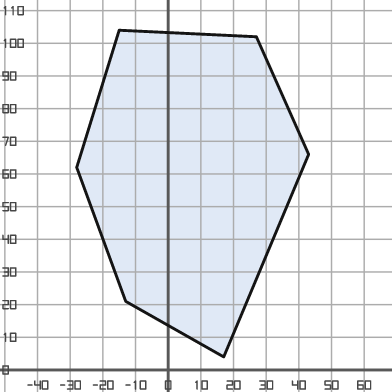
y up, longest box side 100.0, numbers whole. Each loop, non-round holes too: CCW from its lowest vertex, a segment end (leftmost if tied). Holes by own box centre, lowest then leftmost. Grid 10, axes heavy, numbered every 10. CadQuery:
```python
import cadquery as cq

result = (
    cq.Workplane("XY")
    .moveTo(17.0, 4.0)
    .lineTo(43.0, 66.0)
    .lineTo(27.0, 102.0)
    .lineTo(-15.0, 104.0)
    .lineTo(-28.0, 62.0)
    .lineTo(-13.0, 21.0)
    .close()
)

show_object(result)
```